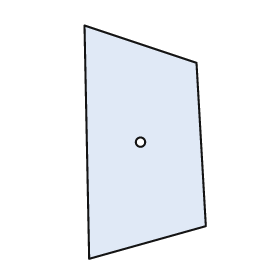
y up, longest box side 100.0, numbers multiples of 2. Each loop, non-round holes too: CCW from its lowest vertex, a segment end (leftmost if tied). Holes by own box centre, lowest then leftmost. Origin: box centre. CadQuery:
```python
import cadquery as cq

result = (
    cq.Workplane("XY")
    .moveTo(-24.0, -50.0)
    .lineTo(26.0, -36.0)
    .lineTo(22.0, 34.0)
    .lineTo(-26.0, 50.0)
    .close()
    .moveTo(-2.0, 0.0)
    .circle(2.0)
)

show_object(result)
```